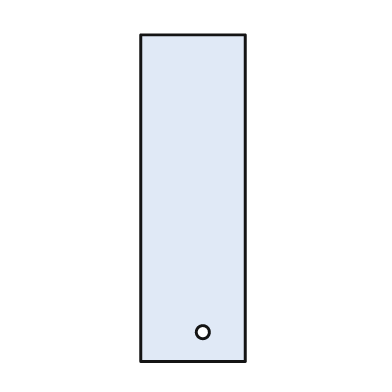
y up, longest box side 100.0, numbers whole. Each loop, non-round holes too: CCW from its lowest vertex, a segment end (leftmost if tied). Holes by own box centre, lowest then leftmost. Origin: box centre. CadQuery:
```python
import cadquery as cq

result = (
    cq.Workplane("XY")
    .moveTo(-16.0, -50.0)
    .lineTo(16.0, -50.0)
    .lineTo(16.0, 50.0)
    .lineTo(-16.0, 50.0)
    .close()
    .moveTo(3.0, -41.0)
    .circle(2.0)
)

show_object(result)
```